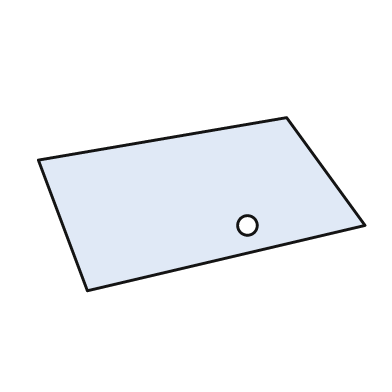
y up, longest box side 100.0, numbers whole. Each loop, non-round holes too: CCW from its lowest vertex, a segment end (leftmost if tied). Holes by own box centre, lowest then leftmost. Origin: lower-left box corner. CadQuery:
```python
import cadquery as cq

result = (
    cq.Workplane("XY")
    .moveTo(15.0, 0.0)
    .lineTo(100.0, 20.0)
    .lineTo(76.0, 53.0)
    .lineTo(0.0, 40.0)
    .close()
    .moveTo(64.0, 20.0)
    .circle(3.0)
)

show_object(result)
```